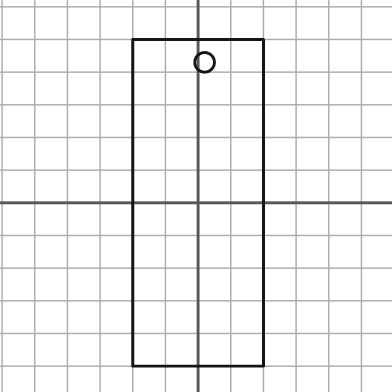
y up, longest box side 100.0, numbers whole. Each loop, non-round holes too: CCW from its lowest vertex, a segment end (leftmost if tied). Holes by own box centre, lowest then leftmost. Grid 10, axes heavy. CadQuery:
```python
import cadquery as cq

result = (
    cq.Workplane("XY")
    .moveTo(-20.0, -50.0)
    .lineTo(20.0, -50.0)
    .lineTo(20.0, 50.0)
    .lineTo(-20.0, 50.0)
    .close()
    .moveTo(2.0, 43.0)
    .circle(3.0)
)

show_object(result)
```